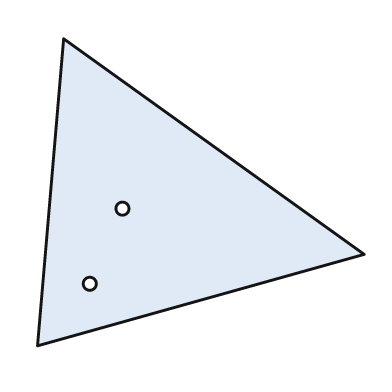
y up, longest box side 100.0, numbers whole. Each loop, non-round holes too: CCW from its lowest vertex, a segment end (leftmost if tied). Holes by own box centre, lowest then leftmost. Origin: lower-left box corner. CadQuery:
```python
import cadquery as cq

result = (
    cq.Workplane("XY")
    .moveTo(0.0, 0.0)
    .lineTo(100.0, 28.0)
    .lineTo(8.0, 94.0)
    .close()
    .moveTo(16.0, 19.0)
    .circle(2.0)
    .moveTo(26.0, 42.0)
    .circle(2.0)
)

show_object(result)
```